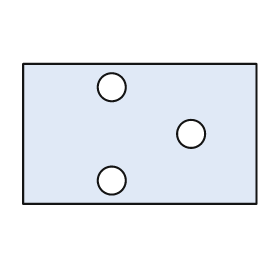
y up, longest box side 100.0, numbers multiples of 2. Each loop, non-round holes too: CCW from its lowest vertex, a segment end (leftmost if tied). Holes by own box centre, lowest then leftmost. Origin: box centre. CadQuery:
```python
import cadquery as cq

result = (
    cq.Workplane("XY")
    .moveTo(-50.0, -30.0)
    .lineTo(50.0, -30.0)
    .lineTo(50.0, 30.0)
    .lineTo(-50.0, 30.0)
    .close()
    .moveTo(-12.0, -20.0)
    .circle(6.0)
    .moveTo(22.0, 0.0)
    .circle(6.0)
    .moveTo(-12.0, 20.0)
    .circle(6.0)
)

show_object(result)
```